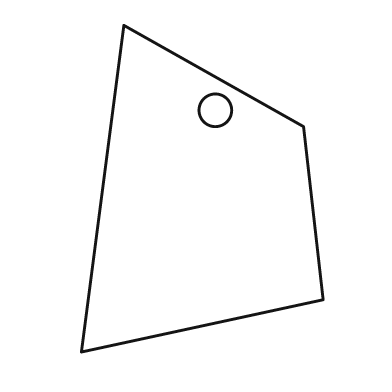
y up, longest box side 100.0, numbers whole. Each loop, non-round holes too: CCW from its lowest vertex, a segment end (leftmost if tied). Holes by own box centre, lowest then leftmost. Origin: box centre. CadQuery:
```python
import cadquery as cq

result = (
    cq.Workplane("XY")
    .moveTo(-37.0, -50.0)
    .lineTo(37.0, -34.0)
    .lineTo(31.0, 19.0)
    .lineTo(-24.0, 50.0)
    .close()
    .moveTo(4.0, 24.0)
    .circle(5.0)
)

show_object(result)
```